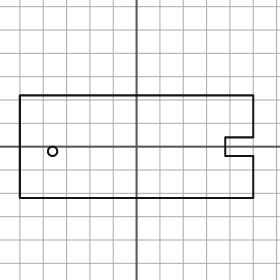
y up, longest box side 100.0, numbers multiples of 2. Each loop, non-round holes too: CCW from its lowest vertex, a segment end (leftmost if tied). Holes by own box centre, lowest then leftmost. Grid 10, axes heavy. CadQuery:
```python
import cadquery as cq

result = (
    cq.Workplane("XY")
    .moveTo(-50.0, -22.0)
    .lineTo(50.0, -22.0)
    .lineTo(50.0, -4.0)
    .lineTo(38.0, -4.0)
    .lineTo(38.0, 4.0)
    .lineTo(50.0, 4.0)
    .lineTo(50.0, 22.0)
    .lineTo(-50.0, 22.0)
    .close()
    .moveTo(-36.0, -2.0)
    .circle(2.0)
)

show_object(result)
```